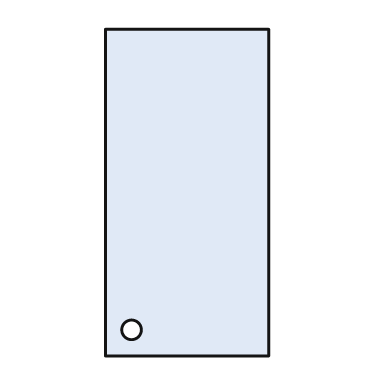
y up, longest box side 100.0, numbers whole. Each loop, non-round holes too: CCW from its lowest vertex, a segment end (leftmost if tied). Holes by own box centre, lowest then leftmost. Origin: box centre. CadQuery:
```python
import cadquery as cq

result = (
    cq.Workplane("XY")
    .moveTo(-25.0, -50.0)
    .lineTo(25.0, -50.0)
    .lineTo(25.0, 50.0)
    .lineTo(-25.0, 50.0)
    .close()
    .moveTo(-17.0, -42.0)
    .circle(3.0)
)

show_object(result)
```